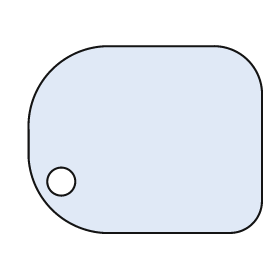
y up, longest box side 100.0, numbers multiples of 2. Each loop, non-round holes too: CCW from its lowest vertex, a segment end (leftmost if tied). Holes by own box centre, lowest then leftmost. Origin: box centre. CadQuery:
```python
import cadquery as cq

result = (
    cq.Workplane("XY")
    .moveTo(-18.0, -40.0)
    .lineTo(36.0, -40.0)
    .threePointArc((46.0, -36.0), (50.0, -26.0))
    .lineTo(50.0, 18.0)
    .threePointArc((44.0, 34.0), (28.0, 40.0))
    .lineTo(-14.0, 40.0)
    .threePointArc((-40.0, 30.0), (-50.0, 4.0))
    .lineTo(-50.0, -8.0)
    .threePointArc((-40.0, -30.0), (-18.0, -40.0))
    .close()
    .moveTo(-36.0, -18.0)
    .circle(6.0)
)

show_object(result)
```